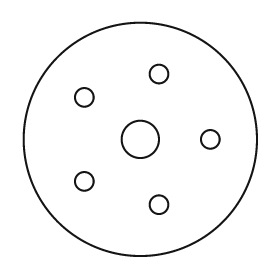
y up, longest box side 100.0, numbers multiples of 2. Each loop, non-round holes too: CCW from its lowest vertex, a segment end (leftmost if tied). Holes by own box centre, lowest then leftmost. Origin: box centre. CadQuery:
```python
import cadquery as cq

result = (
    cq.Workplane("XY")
    .moveTo(0.0, 0.0)
    .circle(50.0)
    .moveTo(8.0, -28.0)
    .circle(4.0)
    .moveTo(-24.0, -18.0)
    .circle(4.0)
    .moveTo(0.0, 0.0)
    .circle(8.0)
    .moveTo(30.0, 0.0)
    .circle(4.0)
    .moveTo(-24.0, 18.0)
    .circle(4.0)
    .moveTo(8.0, 28.0)
    .circle(4.0)
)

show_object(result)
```